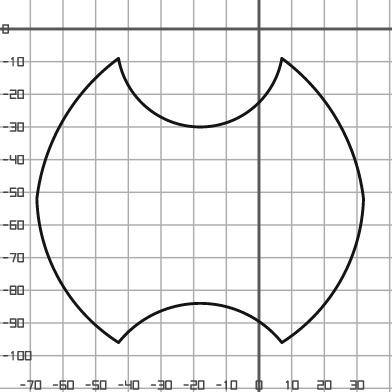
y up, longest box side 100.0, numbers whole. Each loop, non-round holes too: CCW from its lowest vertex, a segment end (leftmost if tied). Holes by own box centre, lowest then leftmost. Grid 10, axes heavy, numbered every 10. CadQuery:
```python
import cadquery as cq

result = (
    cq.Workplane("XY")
    .moveTo(-43.0, -96.0)
    .threePointArc((-18.0, -84.0), (7.0, -96.0))
    .threePointArc((25.0, -77.0), (32.0, -52.0))
    .threePointArc((24.0, -28.0), (7.0, -9.0))
    .threePointArc((-18.0, -30.0), (-43.0, -9.0))
    .threePointArc((-60.0, -28.0), (-68.0, -52.0))
    .threePointArc((-61.0, -77.0), (-43.0, -96.0))
    .close()
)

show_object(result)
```